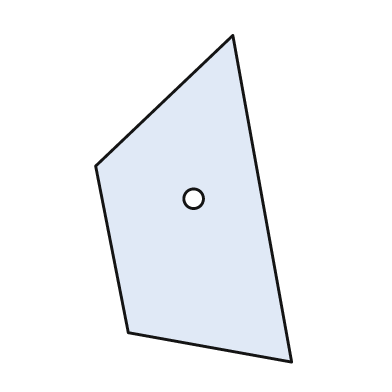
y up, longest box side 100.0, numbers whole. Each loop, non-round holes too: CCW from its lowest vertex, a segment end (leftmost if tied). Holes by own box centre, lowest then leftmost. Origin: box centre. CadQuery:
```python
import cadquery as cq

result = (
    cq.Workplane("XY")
    .moveTo(30.0, -50.0)
    .lineTo(12.0, 50.0)
    .lineTo(-30.0, 10.0)
    .lineTo(-20.0, -41.0)
    .close()
    .moveTo(0.0, 0.0)
    .circle(3.0)
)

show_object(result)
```